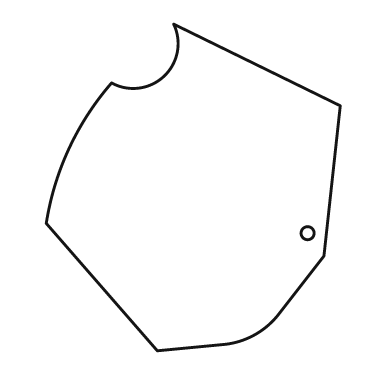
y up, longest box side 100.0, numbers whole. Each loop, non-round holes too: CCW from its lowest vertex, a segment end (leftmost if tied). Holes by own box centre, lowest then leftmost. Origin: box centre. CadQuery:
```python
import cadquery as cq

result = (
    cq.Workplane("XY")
    .moveTo(-11.0, -50.0)
    .lineTo(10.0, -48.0)
    .threePointArc((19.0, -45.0), (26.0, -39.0))
    .lineTo(40.0, -21.0)
    .lineTo(45.0, 25.0)
    .lineTo(-6.0, 50.0)
    .threePointArc((-9.0, 34.0), (-25.0, 32.0))
    .threePointArc((-38.0, 12.0), (-45.0, -11.0))
    .close()
    .moveTo(35.0, -14.0)
    .circle(2.0)
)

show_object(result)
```